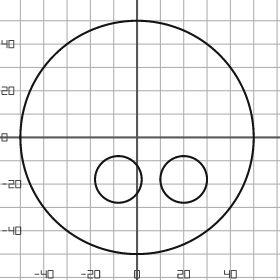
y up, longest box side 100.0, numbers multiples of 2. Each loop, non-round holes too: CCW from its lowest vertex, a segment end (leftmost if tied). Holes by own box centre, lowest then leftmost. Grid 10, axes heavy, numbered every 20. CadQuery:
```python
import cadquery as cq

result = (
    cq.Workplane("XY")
    .moveTo(0.0, 0.0)
    .circle(50.0)
    .moveTo(-8.0, -18.0)
    .circle(10.0)
    .moveTo(20.0, -18.0)
    .circle(10.0)
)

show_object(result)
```